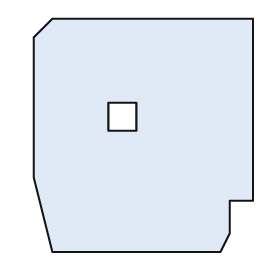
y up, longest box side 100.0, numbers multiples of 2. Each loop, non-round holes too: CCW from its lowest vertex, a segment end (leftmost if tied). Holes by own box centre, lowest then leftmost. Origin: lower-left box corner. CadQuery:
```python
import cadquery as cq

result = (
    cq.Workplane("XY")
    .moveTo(8.0, 0.0)
    .lineTo(80.0, 0.0)
    .lineTo(84.0, 8.0)
    .lineTo(84.0, 22.0)
    .lineTo(94.0, 22.0)
    .lineTo(94.0, 100.0)
    .lineTo(8.0, 100.0)
    .lineTo(0.0, 92.0)
    .lineTo(0.0, 32.0)
    .close()
    .moveTo(32.0, 52.0)
    .lineTo(44.0, 52.0)
    .lineTo(44.0, 64.0)
    .lineTo(32.0, 64.0)
    .close()
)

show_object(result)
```